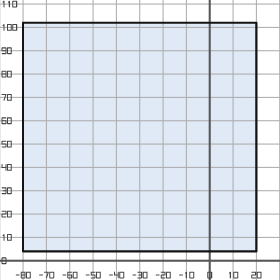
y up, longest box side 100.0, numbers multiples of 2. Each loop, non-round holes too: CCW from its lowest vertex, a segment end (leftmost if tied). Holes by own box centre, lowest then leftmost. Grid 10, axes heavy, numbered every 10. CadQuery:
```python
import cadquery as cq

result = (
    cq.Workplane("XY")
    .moveTo(-80.0, 4.0)
    .lineTo(20.0, 4.0)
    .lineTo(20.0, 102.0)
    .lineTo(-80.0, 102.0)
    .close()
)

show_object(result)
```